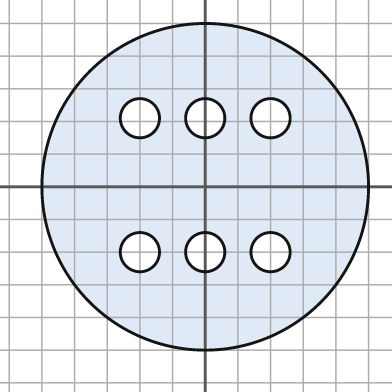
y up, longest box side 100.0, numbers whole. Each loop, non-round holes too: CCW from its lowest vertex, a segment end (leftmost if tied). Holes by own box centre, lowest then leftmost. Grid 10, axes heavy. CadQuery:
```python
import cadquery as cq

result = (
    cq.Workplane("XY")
    .moveTo(0.0, 0.0)
    .circle(50.0)
    .moveTo(-20.0, -20.0)
    .circle(6.0)
    .moveTo(0.0, -20.0)
    .circle(6.0)
    .moveTo(20.0, -20.0)
    .circle(6.0)
    .moveTo(-20.0, 21.0)
    .circle(6.0)
    .moveTo(0.0, 21.0)
    .circle(6.0)
    .moveTo(20.0, 21.0)
    .circle(6.0)
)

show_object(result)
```